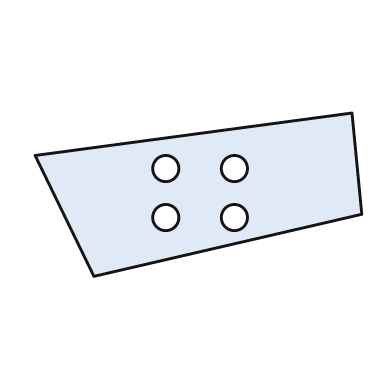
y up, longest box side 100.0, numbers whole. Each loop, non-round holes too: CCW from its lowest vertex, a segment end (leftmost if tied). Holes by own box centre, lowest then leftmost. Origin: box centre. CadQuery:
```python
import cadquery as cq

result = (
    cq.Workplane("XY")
    .moveTo(-32.0, -25.0)
    .lineTo(50.0, -6.0)
    .lineTo(47.0, 25.0)
    .lineTo(-50.0, 12.0)
    .close()
    .moveTo(-10.0, -7.0)
    .circle(4.0)
    .moveTo(11.0, -7.0)
    .circle(4.0)
    .moveTo(-10.0, 8.0)
    .circle(4.0)
    .moveTo(11.0, 8.0)
    .circle(4.0)
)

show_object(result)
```